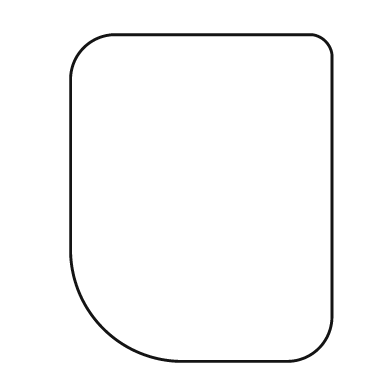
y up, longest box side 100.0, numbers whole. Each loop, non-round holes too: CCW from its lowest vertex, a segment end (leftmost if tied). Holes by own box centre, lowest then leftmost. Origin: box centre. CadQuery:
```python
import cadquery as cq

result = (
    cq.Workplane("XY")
    .moveTo(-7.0, -50.0)
    .lineTo(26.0, -50.0)
    .threePointArc((36.0, -46.0), (40.0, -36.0))
    .lineTo(40.0, 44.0)
    .threePointArc((38.0, 48.0), (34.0, 50.0))
    .lineTo(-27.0, 50.0)
    .threePointArc((-36.0, 46.0), (-40.0, 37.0))
    .lineTo(-40.0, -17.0)
    .threePointArc((-30.0, -40.0), (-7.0, -50.0))
    .close()
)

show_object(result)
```